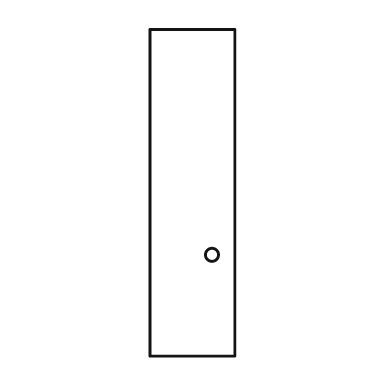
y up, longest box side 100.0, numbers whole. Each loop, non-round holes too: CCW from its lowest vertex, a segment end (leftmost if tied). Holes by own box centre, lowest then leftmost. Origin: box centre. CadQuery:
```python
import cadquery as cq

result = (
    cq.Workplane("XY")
    .moveTo(-13.0, -50.0)
    .lineTo(13.0, -50.0)
    .lineTo(13.0, 50.0)
    .lineTo(-13.0, 50.0)
    .close()
    .moveTo(6.0, -19.0)
    .circle(2.0)
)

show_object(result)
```